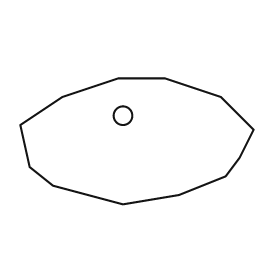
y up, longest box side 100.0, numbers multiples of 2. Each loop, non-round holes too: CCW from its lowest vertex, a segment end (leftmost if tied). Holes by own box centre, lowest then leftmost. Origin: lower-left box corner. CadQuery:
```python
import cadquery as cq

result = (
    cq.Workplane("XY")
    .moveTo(44.0, 0.0)
    .lineTo(68.0, 4.0)
    .lineTo(88.0, 12.0)
    .lineTo(94.0, 20.0)
    .lineTo(100.0, 32.0)
    .lineTo(86.0, 46.0)
    .lineTo(62.0, 54.0)
    .lineTo(42.0, 54.0)
    .lineTo(18.0, 46.0)
    .lineTo(0.0, 34.0)
    .lineTo(4.0, 16.0)
    .lineTo(14.0, 8.0)
    .close()
    .moveTo(44.0, 38.0)
    .circle(4.0)
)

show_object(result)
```